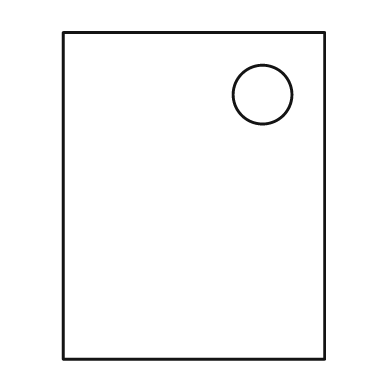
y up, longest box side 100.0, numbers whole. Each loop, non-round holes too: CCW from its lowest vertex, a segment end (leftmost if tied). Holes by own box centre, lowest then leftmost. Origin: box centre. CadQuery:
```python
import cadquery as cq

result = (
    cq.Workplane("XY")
    .moveTo(-40.0, -50.0)
    .lineTo(40.0, -50.0)
    .lineTo(40.0, 50.0)
    .lineTo(-40.0, 50.0)
    .close()
    .moveTo(21.0, 31.0)
    .circle(9.0)
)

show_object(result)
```